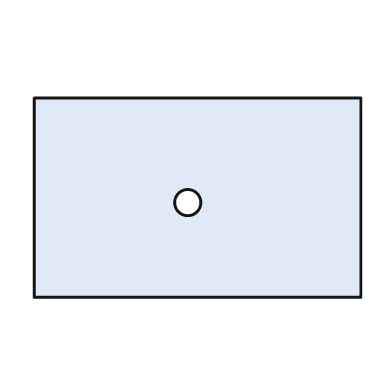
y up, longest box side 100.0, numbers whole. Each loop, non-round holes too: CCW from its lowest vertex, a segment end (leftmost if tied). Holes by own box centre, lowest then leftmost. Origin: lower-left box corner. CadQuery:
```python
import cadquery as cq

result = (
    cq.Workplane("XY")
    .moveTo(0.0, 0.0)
    .lineTo(100.0, 0.0)
    .lineTo(100.0, 61.0)
    .lineTo(0.0, 61.0)
    .close()
    .moveTo(47.0, 29.0)
    .circle(4.0)
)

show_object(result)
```